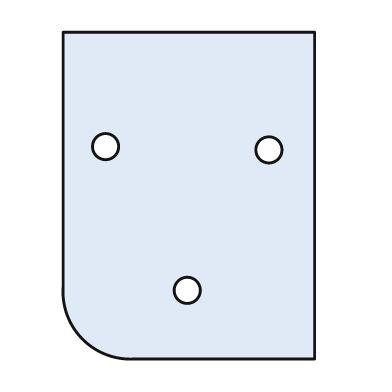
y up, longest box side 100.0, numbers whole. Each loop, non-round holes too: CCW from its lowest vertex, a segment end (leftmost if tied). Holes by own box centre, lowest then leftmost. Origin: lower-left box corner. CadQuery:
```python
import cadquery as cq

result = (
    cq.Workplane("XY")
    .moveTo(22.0, 0.0)
    .lineTo(77.0, 0.0)
    .lineTo(77.0, 100.0)
    .lineTo(0.0, 100.0)
    .lineTo(0.0, 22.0)
    .threePointArc((6.0, 6.0), (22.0, 0.0))
    .close()
    .moveTo(38.0, 21.0)
    .circle(4.0)
    .moveTo(63.0, 64.0)
    .circle(4.0)
    .moveTo(13.0, 65.0)
    .circle(4.0)
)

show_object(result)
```